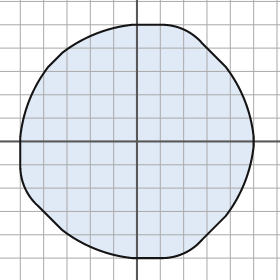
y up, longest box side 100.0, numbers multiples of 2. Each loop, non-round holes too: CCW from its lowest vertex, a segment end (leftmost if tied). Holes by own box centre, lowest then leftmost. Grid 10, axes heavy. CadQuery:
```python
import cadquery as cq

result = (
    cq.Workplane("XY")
    .moveTo(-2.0, -50.0)
    .lineTo(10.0, -50.0)
    .threePointArc((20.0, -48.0), (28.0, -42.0))
    .lineTo(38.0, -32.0)
    .threePointArc((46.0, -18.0), (50.0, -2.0))
    .lineTo(50.0, 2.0)
    .threePointArc((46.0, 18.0), (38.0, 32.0))
    .lineTo(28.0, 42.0)
    .threePointArc((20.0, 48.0), (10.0, 50.0))
    .lineTo(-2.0, 50.0)
    .threePointArc((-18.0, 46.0), (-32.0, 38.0))
    .lineTo(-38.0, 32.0)
    .threePointArc((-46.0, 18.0), (-50.0, 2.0))
    .lineTo(-50.0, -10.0)
    .threePointArc((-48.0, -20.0), (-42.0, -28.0))
    .lineTo(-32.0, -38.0)
    .threePointArc((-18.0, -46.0), (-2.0, -50.0))
    .close()
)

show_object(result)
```